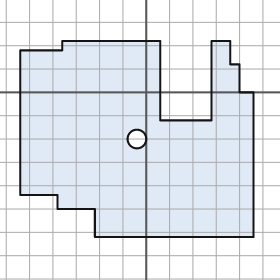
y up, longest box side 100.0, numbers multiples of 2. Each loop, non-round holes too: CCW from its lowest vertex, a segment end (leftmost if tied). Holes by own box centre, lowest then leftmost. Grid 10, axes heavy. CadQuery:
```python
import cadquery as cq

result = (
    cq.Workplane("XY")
    .moveTo(-22.0, -62.0)
    .lineTo(46.0, -62.0)
    .lineTo(46.0, 0.0)
    .lineTo(40.0, 0.0)
    .lineTo(40.0, 12.0)
    .lineTo(36.0, 12.0)
    .lineTo(36.0, 22.0)
    .lineTo(28.0, 22.0)
    .lineTo(28.0, -12.0)
    .lineTo(6.0, -12.0)
    .lineTo(6.0, 22.0)
    .lineTo(-36.0, 22.0)
    .lineTo(-36.0, 18.0)
    .lineTo(-54.0, 18.0)
    .lineTo(-54.0, -44.0)
    .lineTo(-38.0, -44.0)
    .lineTo(-38.0, -50.0)
    .lineTo(-22.0, -50.0)
    .close()
    .moveTo(-4.0, -20.0)
    .circle(4.0)
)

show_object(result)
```